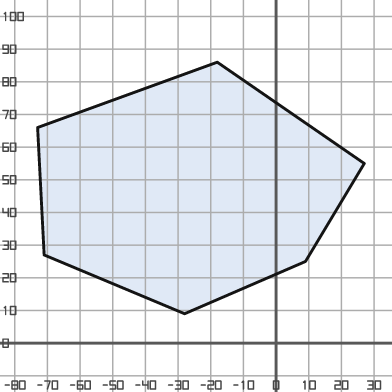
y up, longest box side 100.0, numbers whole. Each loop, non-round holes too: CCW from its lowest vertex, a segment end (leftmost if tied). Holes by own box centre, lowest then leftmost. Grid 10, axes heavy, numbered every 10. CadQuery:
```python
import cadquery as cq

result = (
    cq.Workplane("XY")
    .moveTo(-28.0, 9.0)
    .lineTo(9.0, 25.0)
    .lineTo(27.0, 55.0)
    .lineTo(-18.0, 86.0)
    .lineTo(-73.0, 66.0)
    .lineTo(-71.0, 27.0)
    .close()
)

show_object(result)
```